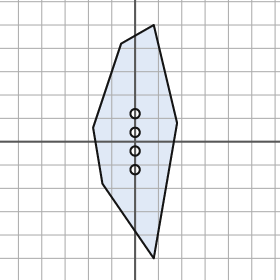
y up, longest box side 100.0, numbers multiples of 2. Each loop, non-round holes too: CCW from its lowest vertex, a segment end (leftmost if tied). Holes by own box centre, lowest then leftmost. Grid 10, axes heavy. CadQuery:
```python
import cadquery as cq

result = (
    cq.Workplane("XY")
    .moveTo(8.0, -50.0)
    .lineTo(18.0, 8.0)
    .lineTo(8.0, 50.0)
    .lineTo(-6.0, 42.0)
    .lineTo(-18.0, 6.0)
    .lineTo(-14.0, -18.0)
    .close()
    .moveTo(0.0, -12.0)
    .circle(2.0)
    .moveTo(0.0, -4.0)
    .circle(2.0)
    .moveTo(0.0, 4.0)
    .circle(2.0)
    .moveTo(0.0, 12.0)
    .circle(2.0)
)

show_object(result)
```